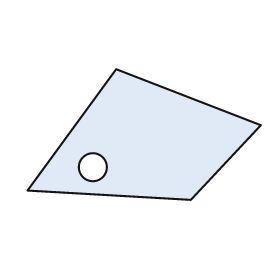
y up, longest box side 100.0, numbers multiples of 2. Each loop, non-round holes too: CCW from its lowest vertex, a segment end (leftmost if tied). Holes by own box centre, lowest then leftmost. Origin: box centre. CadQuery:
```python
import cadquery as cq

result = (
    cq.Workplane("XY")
    .moveTo(20.0, -28.0)
    .lineTo(50.0, 4.0)
    .lineTo(-12.0, 28.0)
    .lineTo(-50.0, -24.0)
    .close()
    .moveTo(-22.0, -14.0)
    .circle(6.0)
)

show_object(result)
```